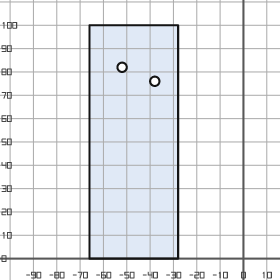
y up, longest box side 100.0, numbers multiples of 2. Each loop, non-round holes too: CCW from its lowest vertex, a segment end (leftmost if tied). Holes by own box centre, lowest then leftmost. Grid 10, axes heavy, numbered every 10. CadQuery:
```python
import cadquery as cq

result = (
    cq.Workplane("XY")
    .moveTo(-66.0, 0.0)
    .lineTo(-28.0, 0.0)
    .lineTo(-28.0, 100.0)
    .lineTo(-66.0, 100.0)
    .close()
    .moveTo(-38.0, 76.0)
    .circle(2.0)
    .moveTo(-52.0, 82.0)
    .circle(2.0)
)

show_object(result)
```